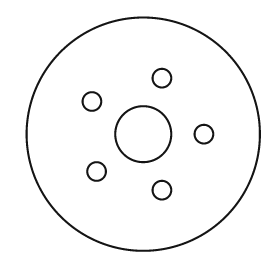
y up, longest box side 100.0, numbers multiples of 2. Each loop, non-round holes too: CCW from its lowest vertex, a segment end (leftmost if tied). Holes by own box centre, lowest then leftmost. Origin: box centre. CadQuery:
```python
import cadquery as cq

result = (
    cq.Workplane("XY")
    .moveTo(0.0, 0.0)
    .circle(50.0)
    .moveTo(8.0, -24.0)
    .circle(4.0)
    .moveTo(-20.0, -16.0)
    .circle(4.0)
    .moveTo(0.0, 0.0)
    .circle(12.0)
    .moveTo(26.0, 0.0)
    .circle(4.0)
    .moveTo(-22.0, 14.0)
    .circle(4.0)
    .moveTo(8.0, 24.0)
    .circle(4.0)
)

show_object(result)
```